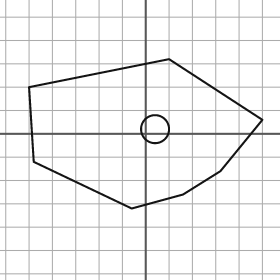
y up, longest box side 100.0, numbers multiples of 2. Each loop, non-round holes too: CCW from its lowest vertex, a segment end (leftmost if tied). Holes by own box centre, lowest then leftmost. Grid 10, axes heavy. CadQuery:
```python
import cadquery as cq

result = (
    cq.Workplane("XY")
    .moveTo(-6.0, -32.0)
    .lineTo(16.0, -26.0)
    .lineTo(32.0, -16.0)
    .lineTo(50.0, 6.0)
    .lineTo(10.0, 32.0)
    .lineTo(-50.0, 20.0)
    .lineTo(-48.0, -12.0)
    .close()
    .moveTo(4.0, 2.0)
    .circle(6.0)
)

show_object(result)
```